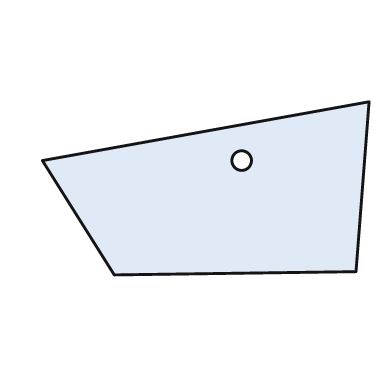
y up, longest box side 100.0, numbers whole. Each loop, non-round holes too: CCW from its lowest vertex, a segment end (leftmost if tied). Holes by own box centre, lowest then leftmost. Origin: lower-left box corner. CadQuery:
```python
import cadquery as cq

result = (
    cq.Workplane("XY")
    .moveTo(22.0, 0.0)
    .lineTo(96.0, 1.0)
    .lineTo(100.0, 53.0)
    .lineTo(0.0, 35.0)
    .close()
    .moveTo(61.0, 35.0)
    .circle(3.0)
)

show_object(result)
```